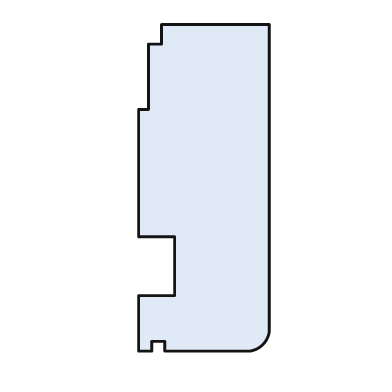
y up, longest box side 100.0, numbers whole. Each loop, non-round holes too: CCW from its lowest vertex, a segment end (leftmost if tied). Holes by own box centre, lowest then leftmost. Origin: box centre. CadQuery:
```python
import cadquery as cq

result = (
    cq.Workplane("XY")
    .moveTo(-20.0, -50.0)
    .lineTo(-16.0, -50.0)
    .lineTo(-16.0, -47.0)
    .lineTo(-12.0, -47.0)
    .lineTo(-12.0, -50.0)
    .lineTo(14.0, -50.0)
    .threePointArc((18.0, -48.0), (20.0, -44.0))
    .lineTo(20.0, 50.0)
    .lineTo(-13.0, 50.0)
    .lineTo(-13.0, 44.0)
    .lineTo(-17.0, 44.0)
    .lineTo(-17.0, 24.0)
    .lineTo(-20.0, 24.0)
    .lineTo(-20.0, -15.0)
    .lineTo(-9.0, -15.0)
    .lineTo(-9.0, -33.0)
    .lineTo(-20.0, -33.0)
    .close()
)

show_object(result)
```